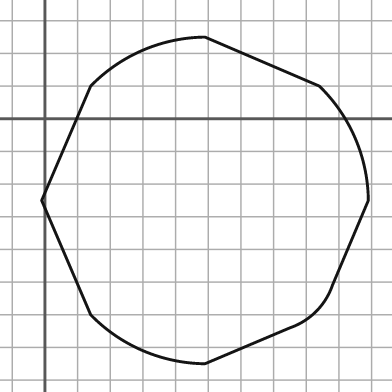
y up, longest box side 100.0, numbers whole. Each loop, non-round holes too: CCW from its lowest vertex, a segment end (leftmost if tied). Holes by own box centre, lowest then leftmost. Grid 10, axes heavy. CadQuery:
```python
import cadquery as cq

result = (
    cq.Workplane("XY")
    .moveTo(49.0, -75.0)
    .lineTo(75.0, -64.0)
    .threePointArc((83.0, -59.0), (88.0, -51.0))
    .lineTo(99.0, -25.0)
    .threePointArc((95.0, -6.0), (84.0, 10.0))
    .lineTo(49.0, 25.0)
    .threePointArc((30.0, 21.0), (14.0, 10.0))
    .lineTo(-1.0, -25.0)
    .lineTo(14.0, -60.0)
    .threePointArc((30.0, -71.0), (49.0, -75.0))
    .close()
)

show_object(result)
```